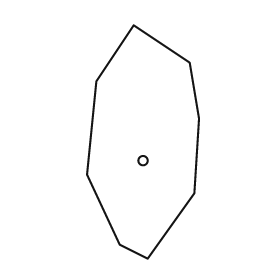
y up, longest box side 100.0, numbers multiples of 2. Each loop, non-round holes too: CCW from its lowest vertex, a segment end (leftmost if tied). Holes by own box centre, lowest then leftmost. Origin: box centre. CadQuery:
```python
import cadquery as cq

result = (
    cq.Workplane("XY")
    .moveTo(2.0, -50.0)
    .lineTo(22.0, -22.0)
    .lineTo(24.0, 10.0)
    .lineTo(20.0, 34.0)
    .lineTo(-4.0, 50.0)
    .lineTo(-20.0, 26.0)
    .lineTo(-24.0, -14.0)
    .lineTo(-10.0, -44.0)
    .close()
    .moveTo(0.0, -8.0)
    .circle(2.0)
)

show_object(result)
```